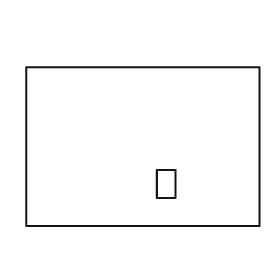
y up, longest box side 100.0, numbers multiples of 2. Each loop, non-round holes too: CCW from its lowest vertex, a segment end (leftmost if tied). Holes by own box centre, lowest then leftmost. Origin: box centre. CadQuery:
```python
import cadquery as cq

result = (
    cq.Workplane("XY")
    .moveTo(-50.0, -34.0)
    .lineTo(50.0, -34.0)
    .lineTo(50.0, 34.0)
    .lineTo(-50.0, 34.0)
    .close()
    .moveTo(6.0, -22.0)
    .lineTo(14.0, -22.0)
    .lineTo(14.0, -10.0)
    .lineTo(6.0, -10.0)
    .close()
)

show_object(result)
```